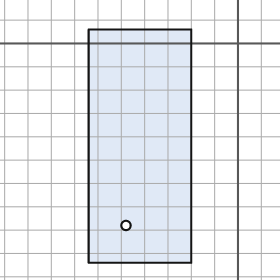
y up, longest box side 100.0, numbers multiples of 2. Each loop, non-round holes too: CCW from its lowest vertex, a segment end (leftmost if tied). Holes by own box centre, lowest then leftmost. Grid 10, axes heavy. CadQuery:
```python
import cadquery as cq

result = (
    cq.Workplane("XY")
    .moveTo(-64.0, -94.0)
    .lineTo(-20.0, -94.0)
    .lineTo(-20.0, 6.0)
    .lineTo(-64.0, 6.0)
    .close()
    .moveTo(-48.0, -78.0)
    .circle(2.0)
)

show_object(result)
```